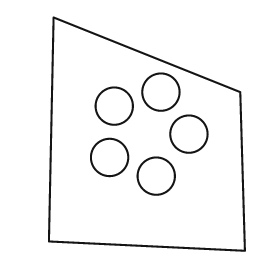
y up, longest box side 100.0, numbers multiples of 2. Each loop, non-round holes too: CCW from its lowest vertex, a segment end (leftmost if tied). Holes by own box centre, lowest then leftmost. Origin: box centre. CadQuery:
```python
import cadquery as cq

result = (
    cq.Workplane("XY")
    .moveTo(42.0, -50.0)
    .lineTo(40.0, 18.0)
    .lineTo(-40.0, 50.0)
    .lineTo(-42.0, -46.0)
    .close()
    .moveTo(4.0, -18.0)
    .circle(8.0)
    .moveTo(-16.0, -10.0)
    .circle(8.0)
    .moveTo(18.0, 0.0)
    .circle(8.0)
    .moveTo(-14.0, 12.0)
    .circle(8.0)
    .moveTo(6.0, 18.0)
    .circle(8.0)
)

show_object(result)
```